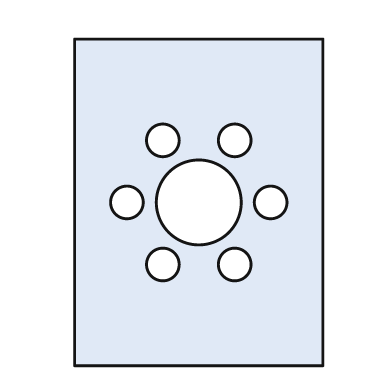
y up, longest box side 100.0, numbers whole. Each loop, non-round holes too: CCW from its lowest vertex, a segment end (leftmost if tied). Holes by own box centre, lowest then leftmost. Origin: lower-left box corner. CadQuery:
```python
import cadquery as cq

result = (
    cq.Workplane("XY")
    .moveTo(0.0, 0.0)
    .lineTo(76.0, 0.0)
    .lineTo(76.0, 100.0)
    .lineTo(0.0, 100.0)
    .close()
    .moveTo(27.0, 31.0)
    .circle(5.0)
    .moveTo(49.0, 31.0)
    .circle(5.0)
    .moveTo(16.0, 50.0)
    .circle(5.0)
    .moveTo(38.0, 50.0)
    .circle(13.0)
    .moveTo(60.0, 50.0)
    .circle(5.0)
    .moveTo(27.0, 69.0)
    .circle(5.0)
    .moveTo(49.0, 69.0)
    .circle(5.0)
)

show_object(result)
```